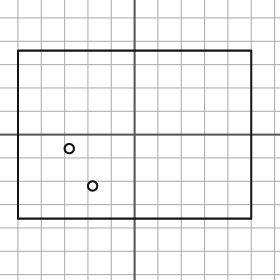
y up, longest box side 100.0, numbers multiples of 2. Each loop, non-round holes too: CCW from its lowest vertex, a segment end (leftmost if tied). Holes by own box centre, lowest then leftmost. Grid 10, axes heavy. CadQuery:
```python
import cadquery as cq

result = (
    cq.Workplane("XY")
    .moveTo(-50.0, -36.0)
    .lineTo(50.0, -36.0)
    .lineTo(50.0, 36.0)
    .lineTo(-50.0, 36.0)
    .close()
    .moveTo(-18.0, -22.0)
    .circle(2.0)
    .moveTo(-28.0, -6.0)
    .circle(2.0)
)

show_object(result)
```